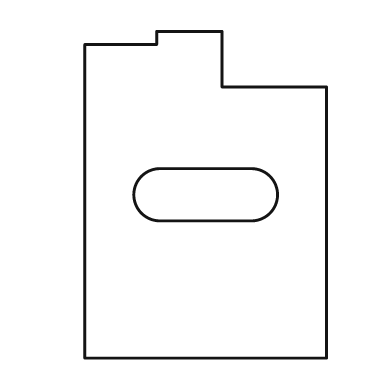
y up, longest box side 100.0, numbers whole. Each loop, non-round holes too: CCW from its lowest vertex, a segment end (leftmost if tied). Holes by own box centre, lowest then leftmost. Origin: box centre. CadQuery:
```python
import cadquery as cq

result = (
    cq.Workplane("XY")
    .moveTo(-37.0, -50.0)
    .lineTo(37.0, -50.0)
    .lineTo(37.0, 33.0)
    .lineTo(5.0, 33.0)
    .lineTo(5.0, 50.0)
    .lineTo(-15.0, 50.0)
    .lineTo(-15.0, 46.0)
    .lineTo(-37.0, 46.0)
    .close()
    .moveTo(-14.0, -8.0)
    .lineTo(14.0, -8.0)
    .threePointArc((22.0, 0.0), (14.0, 8.0))
    .lineTo(-14.0, 8.0)
    .threePointArc((-22.0, 0.0), (-14.0, -8.0))
    .close()
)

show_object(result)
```